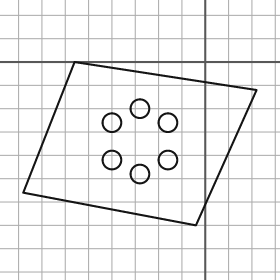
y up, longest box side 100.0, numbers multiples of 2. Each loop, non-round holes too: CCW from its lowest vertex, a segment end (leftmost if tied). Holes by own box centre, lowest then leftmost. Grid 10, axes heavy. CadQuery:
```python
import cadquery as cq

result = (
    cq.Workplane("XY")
    .moveTo(-4.0, -70.0)
    .lineTo(22.0, -12.0)
    .lineTo(-56.0, 0.0)
    .lineTo(-78.0, -56.0)
    .close()
    .moveTo(-28.0, -48.0)
    .circle(4.0)
    .moveTo(-40.0, -42.0)
    .circle(4.0)
    .moveTo(-16.0, -42.0)
    .circle(4.0)
    .moveTo(-40.0, -26.0)
    .circle(4.0)
    .moveTo(-16.0, -26.0)
    .circle(4.0)
    .moveTo(-28.0, -20.0)
    .circle(4.0)
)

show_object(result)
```